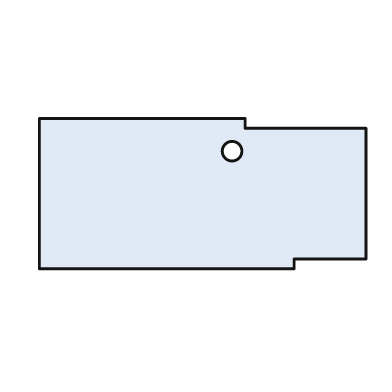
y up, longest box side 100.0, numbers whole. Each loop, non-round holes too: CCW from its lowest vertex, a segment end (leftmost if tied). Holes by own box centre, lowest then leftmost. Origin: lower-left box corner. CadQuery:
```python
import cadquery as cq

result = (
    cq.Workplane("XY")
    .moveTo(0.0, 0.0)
    .lineTo(78.0, 0.0)
    .lineTo(78.0, 3.0)
    .lineTo(100.0, 3.0)
    .lineTo(100.0, 43.0)
    .lineTo(63.0, 43.0)
    .lineTo(63.0, 46.0)
    .lineTo(0.0, 46.0)
    .close()
    .moveTo(59.0, 36.0)
    .circle(3.0)
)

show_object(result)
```